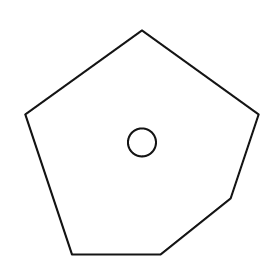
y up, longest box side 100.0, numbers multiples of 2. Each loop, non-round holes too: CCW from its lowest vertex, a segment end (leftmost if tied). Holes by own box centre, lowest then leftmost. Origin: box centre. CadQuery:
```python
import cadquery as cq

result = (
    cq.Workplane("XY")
    .moveTo(-30.0, -48.0)
    .lineTo(8.0, -48.0)
    .lineTo(38.0, -24.0)
    .lineTo(50.0, 12.0)
    .lineTo(0.0, 48.0)
    .lineTo(-50.0, 12.0)
    .close()
    .moveTo(0.0, 0.0)
    .circle(6.0)
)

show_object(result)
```